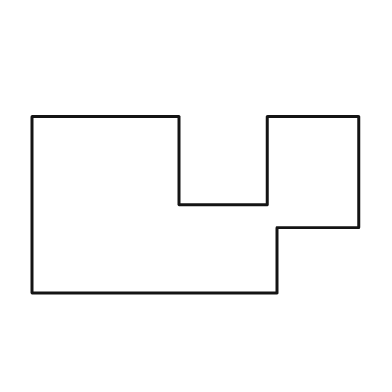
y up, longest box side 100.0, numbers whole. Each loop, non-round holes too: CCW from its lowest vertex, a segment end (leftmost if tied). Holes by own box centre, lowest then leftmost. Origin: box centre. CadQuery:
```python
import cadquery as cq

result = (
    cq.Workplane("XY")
    .moveTo(-50.0, -27.0)
    .lineTo(25.0, -27.0)
    .lineTo(25.0, -7.0)
    .lineTo(50.0, -7.0)
    .lineTo(50.0, 27.0)
    .lineTo(22.0, 27.0)
    .lineTo(22.0, 0.0)
    .lineTo(-5.0, 0.0)
    .lineTo(-5.0, 27.0)
    .lineTo(-50.0, 27.0)
    .close()
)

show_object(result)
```